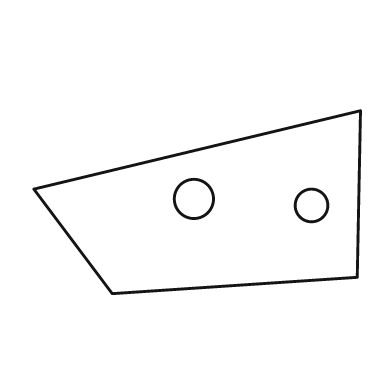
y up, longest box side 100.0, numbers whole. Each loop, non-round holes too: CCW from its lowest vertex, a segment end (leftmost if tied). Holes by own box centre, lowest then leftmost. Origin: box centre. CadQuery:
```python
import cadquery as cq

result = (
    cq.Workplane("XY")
    .moveTo(-26.0, -28.0)
    .lineTo(49.0, -23.0)
    .lineTo(50.0, 28.0)
    .lineTo(-50.0, 4.0)
    .close()
    .moveTo(35.0, -1.0)
    .circle(5.0)
    .moveTo(-1.0, 1.0)
    .circle(6.0)
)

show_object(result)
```